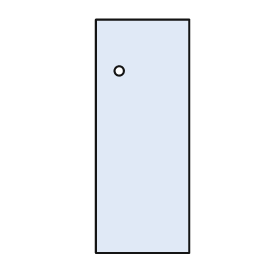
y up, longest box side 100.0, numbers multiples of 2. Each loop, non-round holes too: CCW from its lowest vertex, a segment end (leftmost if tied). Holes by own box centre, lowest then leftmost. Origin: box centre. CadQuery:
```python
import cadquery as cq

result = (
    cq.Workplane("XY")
    .moveTo(-20.0, -50.0)
    .lineTo(20.0, -50.0)
    .lineTo(20.0, 50.0)
    .lineTo(-20.0, 50.0)
    .close()
    .moveTo(-10.0, 28.0)
    .circle(2.0)
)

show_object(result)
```